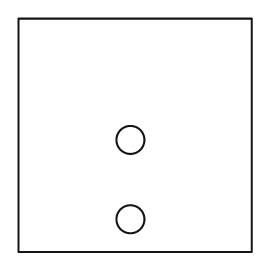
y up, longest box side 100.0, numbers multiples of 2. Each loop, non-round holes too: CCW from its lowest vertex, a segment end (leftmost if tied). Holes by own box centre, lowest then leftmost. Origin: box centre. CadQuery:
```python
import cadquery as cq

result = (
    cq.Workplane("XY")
    .moveTo(-50.0, -50.0)
    .lineTo(50.0, -50.0)
    .lineTo(50.0, 50.0)
    .lineTo(-50.0, 50.0)
    .close()
    .moveTo(-2.0, -36.0)
    .circle(6.0)
    .moveTo(-2.0, -2.0)
    .circle(6.0)
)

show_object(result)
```